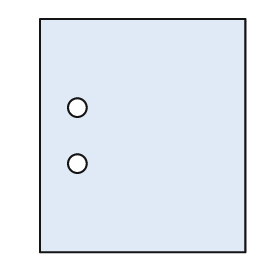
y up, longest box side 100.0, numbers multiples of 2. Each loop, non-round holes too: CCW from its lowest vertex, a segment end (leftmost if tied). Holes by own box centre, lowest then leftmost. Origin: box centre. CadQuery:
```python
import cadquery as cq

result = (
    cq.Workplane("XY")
    .moveTo(-44.0, -50.0)
    .lineTo(44.0, -50.0)
    .lineTo(44.0, 50.0)
    .lineTo(-44.0, 50.0)
    .close()
    .moveTo(-28.0, -12.0)
    .circle(4.0)
    .moveTo(-28.0, 12.0)
    .circle(4.0)
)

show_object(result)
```